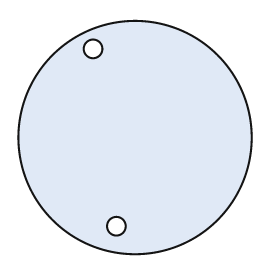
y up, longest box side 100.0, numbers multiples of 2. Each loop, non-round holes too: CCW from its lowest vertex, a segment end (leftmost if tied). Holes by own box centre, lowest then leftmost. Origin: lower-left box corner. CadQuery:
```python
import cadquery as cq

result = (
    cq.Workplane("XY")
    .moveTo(50.0, 50.0)
    .circle(50.0)
    .moveTo(42.0, 12.0)
    .circle(4.0)
    .moveTo(32.0, 88.0)
    .circle(4.0)
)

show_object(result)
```